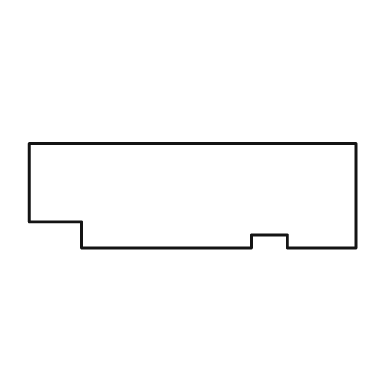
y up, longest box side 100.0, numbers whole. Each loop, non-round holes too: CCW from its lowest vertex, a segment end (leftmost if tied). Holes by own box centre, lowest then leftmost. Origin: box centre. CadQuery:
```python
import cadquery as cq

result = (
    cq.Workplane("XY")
    .moveTo(-34.0, -16.0)
    .lineTo(18.0, -16.0)
    .lineTo(18.0, -12.0)
    .lineTo(29.0, -12.0)
    .lineTo(29.0, -16.0)
    .lineTo(50.0, -16.0)
    .lineTo(50.0, 16.0)
    .lineTo(-50.0, 16.0)
    .lineTo(-50.0, -8.0)
    .lineTo(-34.0, -8.0)
    .close()
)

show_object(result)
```